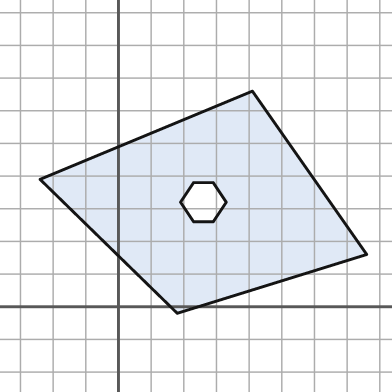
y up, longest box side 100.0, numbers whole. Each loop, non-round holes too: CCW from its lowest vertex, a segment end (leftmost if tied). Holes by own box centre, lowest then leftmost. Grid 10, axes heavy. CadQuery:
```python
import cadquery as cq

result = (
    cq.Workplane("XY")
    .moveTo(18.0, -2.0)
    .lineTo(76.0, 16.0)
    .lineTo(41.0, 66.0)
    .lineTo(-24.0, 39.0)
    .close()
    .moveTo(23.0, 26.0)
    .lineTo(29.0, 26.0)
    .lineTo(33.0, 32.0)
    .lineTo(29.0, 38.0)
    .lineTo(23.0, 38.0)
    .lineTo(19.0, 32.0)
    .close()
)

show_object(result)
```